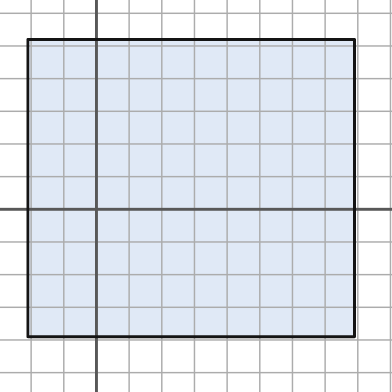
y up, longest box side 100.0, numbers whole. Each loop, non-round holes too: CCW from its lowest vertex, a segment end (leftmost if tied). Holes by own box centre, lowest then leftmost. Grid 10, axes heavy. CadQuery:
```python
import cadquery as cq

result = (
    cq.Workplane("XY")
    .moveTo(-21.0, -39.0)
    .lineTo(79.0, -39.0)
    .lineTo(79.0, 52.0)
    .lineTo(-21.0, 52.0)
    .close()
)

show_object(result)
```